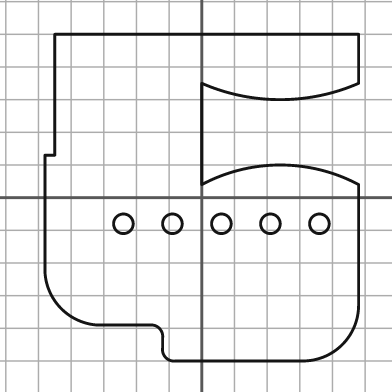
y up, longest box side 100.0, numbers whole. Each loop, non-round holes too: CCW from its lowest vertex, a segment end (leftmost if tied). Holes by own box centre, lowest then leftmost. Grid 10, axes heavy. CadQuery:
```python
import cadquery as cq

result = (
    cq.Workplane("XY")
    .moveTo(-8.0, -50.0)
    .lineTo(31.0, -50.0)
    .threePointArc((43.0, -45.0), (48.0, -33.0))
    .lineTo(48.0, 4.0)
    .threePointArc((24.0, 10.0), (0.0, 4.0))
    .lineTo(0.0, 35.0)
    .threePointArc((24.0, 30.0), (48.0, 35.0))
    .lineTo(48.0, 50.0)
    .lineTo(-45.0, 50.0)
    .lineTo(-45.0, 13.0)
    .lineTo(-48.0, 13.0)
    .lineTo(-48.0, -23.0)
    .threePointArc((-43.0, -34.0), (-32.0, -39.0))
    .lineTo(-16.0, -39.0)
    .threePointArc((-13.0, -40.0), (-12.0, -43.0))
    .lineTo(-12.0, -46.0)
    .threePointArc((-11.0, -49.0), (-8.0, -50.0))
    .close()
    .moveTo(-24.0, -8.0)
    .circle(3.0)
    .moveTo(-9.0, -8.0)
    .circle(3.0)
    .moveTo(6.0, -8.0)
    .circle(3.0)
    .moveTo(21.0, -8.0)
    .circle(3.0)
    .moveTo(36.0, -8.0)
    .circle(3.0)
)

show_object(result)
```